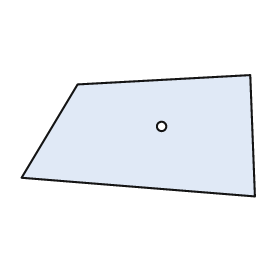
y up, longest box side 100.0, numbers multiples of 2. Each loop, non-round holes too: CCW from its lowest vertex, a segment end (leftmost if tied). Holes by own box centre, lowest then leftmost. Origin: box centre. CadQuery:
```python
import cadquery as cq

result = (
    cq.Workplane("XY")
    .moveTo(50.0, -26.0)
    .lineTo(48.0, 26.0)
    .lineTo(-26.0, 22.0)
    .lineTo(-50.0, -18.0)
    .close()
    .moveTo(10.0, 4.0)
    .circle(2.0)
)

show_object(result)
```